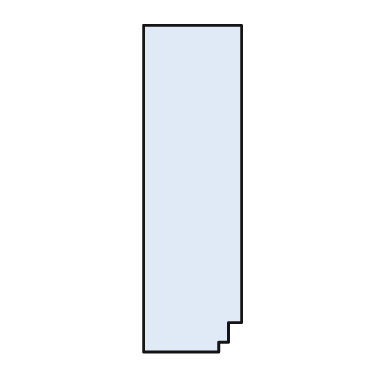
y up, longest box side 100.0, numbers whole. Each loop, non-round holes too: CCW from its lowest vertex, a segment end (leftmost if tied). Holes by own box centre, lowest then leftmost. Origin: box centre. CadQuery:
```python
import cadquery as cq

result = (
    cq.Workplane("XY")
    .moveTo(-15.0, -50.0)
    .lineTo(8.0, -50.0)
    .lineTo(8.0, -47.0)
    .lineTo(11.0, -47.0)
    .lineTo(11.0, -41.0)
    .lineTo(15.0, -41.0)
    .lineTo(15.0, 50.0)
    .lineTo(-15.0, 50.0)
    .close()
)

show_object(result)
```